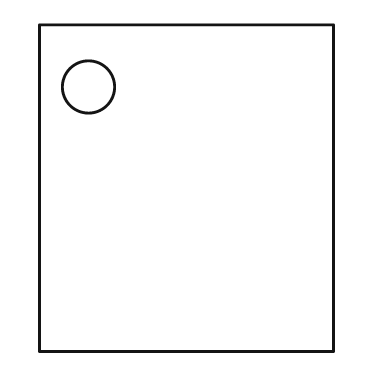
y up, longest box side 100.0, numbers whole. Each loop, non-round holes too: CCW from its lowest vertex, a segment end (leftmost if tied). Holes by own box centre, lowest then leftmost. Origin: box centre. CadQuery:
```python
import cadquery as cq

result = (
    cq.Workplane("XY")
    .moveTo(-45.0, -50.0)
    .lineTo(45.0, -50.0)
    .lineTo(45.0, 50.0)
    .lineTo(-45.0, 50.0)
    .close()
    .moveTo(-30.0, 31.0)
    .circle(8.0)
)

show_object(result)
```